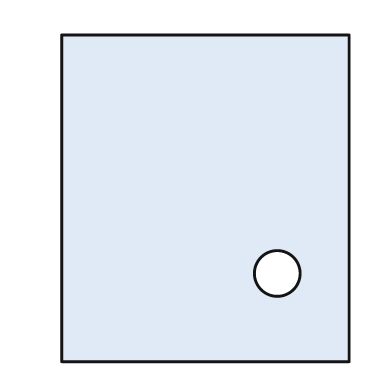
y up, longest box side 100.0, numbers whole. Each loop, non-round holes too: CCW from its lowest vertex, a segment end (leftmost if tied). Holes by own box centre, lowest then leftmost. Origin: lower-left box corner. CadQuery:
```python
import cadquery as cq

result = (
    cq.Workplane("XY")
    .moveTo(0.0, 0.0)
    .lineTo(88.0, 0.0)
    .lineTo(88.0, 100.0)
    .lineTo(0.0, 100.0)
    .close()
    .moveTo(66.0, 27.0)
    .circle(7.0)
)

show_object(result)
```